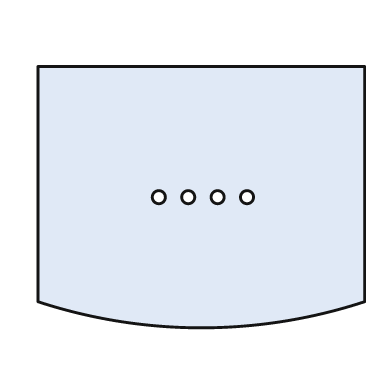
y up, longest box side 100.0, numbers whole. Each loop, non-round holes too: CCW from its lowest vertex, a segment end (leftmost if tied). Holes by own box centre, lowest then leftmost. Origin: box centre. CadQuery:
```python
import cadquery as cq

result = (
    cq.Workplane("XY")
    .moveTo(-50.0, -32.0)
    .threePointArc((0.0, -40.0), (50.0, -32.0))
    .lineTo(50.0, 40.0)
    .lineTo(-50.0, 40.0)
    .close()
    .moveTo(-13.0, 0.0)
    .circle(2.0)
    .moveTo(-4.0, 0.0)
    .circle(2.0)
    .moveTo(5.0, 0.0)
    .circle(2.0)
    .moveTo(14.0, 0.0)
    .circle(2.0)
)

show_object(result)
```